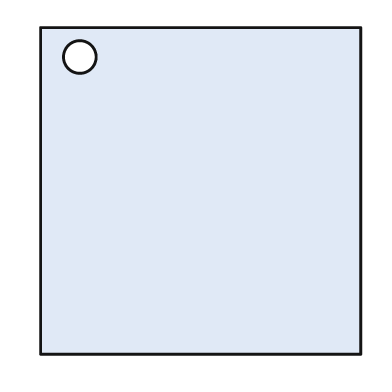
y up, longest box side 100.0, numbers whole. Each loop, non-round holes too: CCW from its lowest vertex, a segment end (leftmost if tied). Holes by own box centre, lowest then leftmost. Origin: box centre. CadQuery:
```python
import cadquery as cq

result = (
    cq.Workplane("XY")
    .moveTo(-49.0, -50.0)
    .lineTo(49.0, -50.0)
    .lineTo(49.0, 50.0)
    .lineTo(-49.0, 50.0)
    .close()
    .moveTo(-37.0, 41.0)
    .circle(5.0)
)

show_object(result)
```